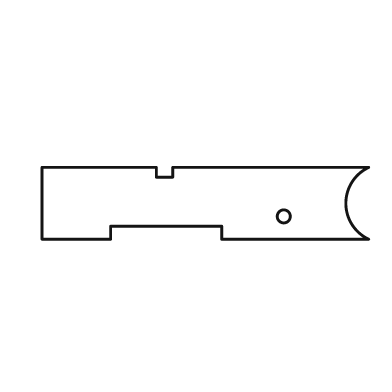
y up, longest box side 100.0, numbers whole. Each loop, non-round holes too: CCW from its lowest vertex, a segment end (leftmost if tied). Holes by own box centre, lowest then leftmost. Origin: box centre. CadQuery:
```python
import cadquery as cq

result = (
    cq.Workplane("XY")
    .moveTo(-50.0, -11.0)
    .lineTo(-29.0, -11.0)
    .lineTo(-29.0, -7.0)
    .lineTo(5.0, -7.0)
    .lineTo(5.0, -11.0)
    .lineTo(50.0, -11.0)
    .threePointArc((43.0, 0.0), (50.0, 11.0))
    .lineTo(-10.0, 11.0)
    .lineTo(-10.0, 8.0)
    .lineTo(-15.0, 8.0)
    .lineTo(-15.0, 11.0)
    .lineTo(-50.0, 11.0)
    .close()
    .moveTo(24.0, -4.0)
    .circle(2.0)
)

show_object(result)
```